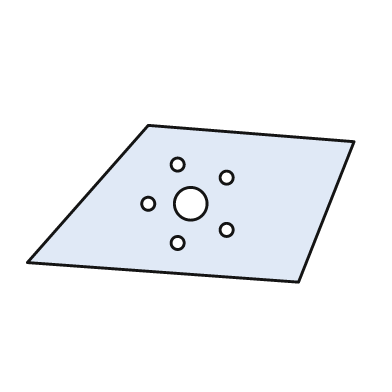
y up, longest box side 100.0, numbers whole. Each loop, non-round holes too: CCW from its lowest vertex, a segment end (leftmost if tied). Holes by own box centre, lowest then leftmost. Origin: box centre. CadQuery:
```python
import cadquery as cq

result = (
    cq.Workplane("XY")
    .moveTo(33.0, -24.0)
    .lineTo(50.0, 19.0)
    .lineTo(-13.0, 24.0)
    .lineTo(-50.0, -18.0)
    .close()
    .moveTo(-4.0, -12.0)
    .circle(2.0)
    .moveTo(11.0, -8.0)
    .circle(2.0)
    .moveTo(-13.0, 0.0)
    .circle(2.0)
    .moveTo(0.0, 0.0)
    .circle(5.0)
    .moveTo(11.0, 8.0)
    .circle(2.0)
    .moveTo(-4.0, 12.0)
    .circle(2.0)
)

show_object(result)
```